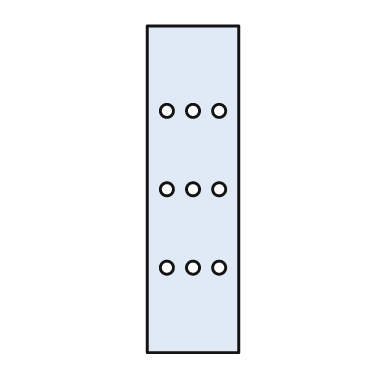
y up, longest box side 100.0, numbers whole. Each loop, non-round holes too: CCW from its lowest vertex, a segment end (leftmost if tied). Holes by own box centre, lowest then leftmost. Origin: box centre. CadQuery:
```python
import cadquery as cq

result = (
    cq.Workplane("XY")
    .moveTo(-14.0, -50.0)
    .lineTo(14.0, -50.0)
    .lineTo(14.0, 50.0)
    .lineTo(-14.0, 50.0)
    .close()
    .moveTo(-8.0, -24.0)
    .circle(2.0)
    .moveTo(0.0, -24.0)
    .circle(2.0)
    .moveTo(8.0, -24.0)
    .circle(2.0)
    .moveTo(-8.0, 0.0)
    .circle(2.0)
    .moveTo(0.0, 0.0)
    .circle(2.0)
    .moveTo(8.0, 0.0)
    .circle(2.0)
    .moveTo(-8.0, 24.0)
    .circle(2.0)
    .moveTo(0.0, 24.0)
    .circle(2.0)
    .moveTo(8.0, 24.0)
    .circle(2.0)
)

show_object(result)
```